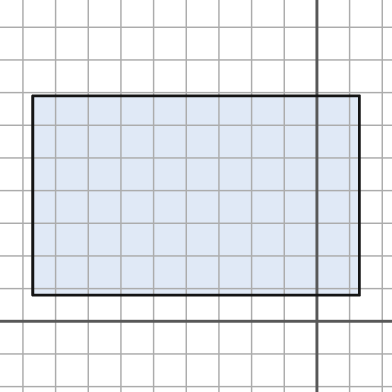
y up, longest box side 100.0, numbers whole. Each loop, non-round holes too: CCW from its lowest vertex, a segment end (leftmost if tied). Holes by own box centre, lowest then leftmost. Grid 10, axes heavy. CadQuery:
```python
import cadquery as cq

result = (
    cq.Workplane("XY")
    .moveTo(-87.0, 8.0)
    .lineTo(13.0, 8.0)
    .lineTo(13.0, 69.0)
    .lineTo(-87.0, 69.0)
    .close()
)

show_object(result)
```